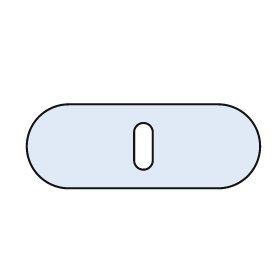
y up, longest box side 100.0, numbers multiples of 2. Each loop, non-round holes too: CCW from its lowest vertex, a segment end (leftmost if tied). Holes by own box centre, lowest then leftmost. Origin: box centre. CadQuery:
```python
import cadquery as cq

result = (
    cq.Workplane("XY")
    .moveTo(-32.0, -18.0)
    .lineTo(32.0, -18.0)
    .threePointArc((50.0, 0.0), (32.0, 18.0))
    .lineTo(-32.0, 18.0)
    .threePointArc((-50.0, 0.0), (-32.0, -18.0))
    .close()
    .moveTo(-4.0, -6.0)
    .threePointArc((0.0, -10.0), (4.0, -6.0))
    .lineTo(4.0, 6.0)
    .threePointArc((0.0, 10.0), (-4.0, 6.0))
    .close()
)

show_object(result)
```